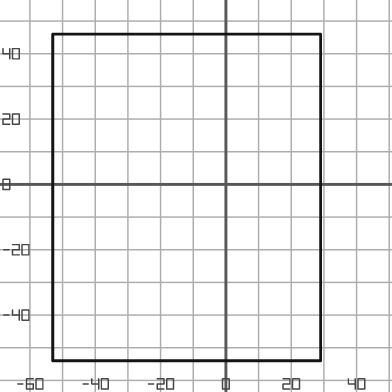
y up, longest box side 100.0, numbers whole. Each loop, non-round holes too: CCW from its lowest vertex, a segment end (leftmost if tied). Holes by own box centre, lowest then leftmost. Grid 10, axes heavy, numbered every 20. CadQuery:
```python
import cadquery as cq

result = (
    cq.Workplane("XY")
    .moveTo(-53.0, -54.0)
    .lineTo(29.0, -54.0)
    .lineTo(29.0, 46.0)
    .lineTo(-53.0, 46.0)
    .close()
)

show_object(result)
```